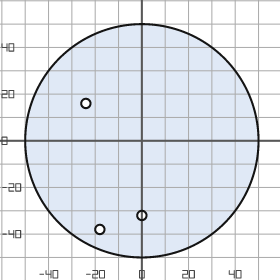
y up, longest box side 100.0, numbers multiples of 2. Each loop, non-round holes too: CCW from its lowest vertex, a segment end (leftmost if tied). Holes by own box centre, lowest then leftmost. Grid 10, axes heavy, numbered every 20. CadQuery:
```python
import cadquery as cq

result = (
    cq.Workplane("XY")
    .moveTo(0.0, 0.0)
    .circle(50.0)
    .moveTo(-18.0, -38.0)
    .circle(2.0)
    .moveTo(0.0, -32.0)
    .circle(2.0)
    .moveTo(-24.0, 16.0)
    .circle(2.0)
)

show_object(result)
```